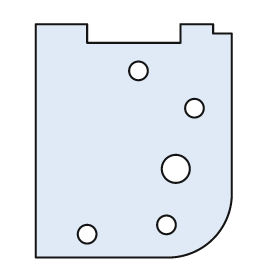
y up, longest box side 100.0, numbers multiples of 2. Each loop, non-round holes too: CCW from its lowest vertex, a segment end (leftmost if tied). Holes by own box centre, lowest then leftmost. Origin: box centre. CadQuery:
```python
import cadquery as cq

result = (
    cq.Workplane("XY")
    .moveTo(-42.0, -50.0)
    .lineTo(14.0, -50.0)
    .threePointArc((34.0, -42.0), (42.0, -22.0))
    .lineTo(42.0, 46.0)
    .lineTo(34.0, 46.0)
    .lineTo(34.0, 50.0)
    .lineTo(20.0, 50.0)
    .lineTo(20.0, 42.0)
    .lineTo(-20.0, 42.0)
    .lineTo(-20.0, 50.0)
    .lineTo(-42.0, 50.0)
    .close()
    .moveTo(-20.0, -40.0)
    .circle(4.0)
    .moveTo(14.0, -36.0)
    .circle(4.0)
    .moveTo(18.0, -12.0)
    .circle(6.0)
    .moveTo(26.0, 14.0)
    .circle(4.0)
    .moveTo(2.0, 30.0)
    .circle(4.0)
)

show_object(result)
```